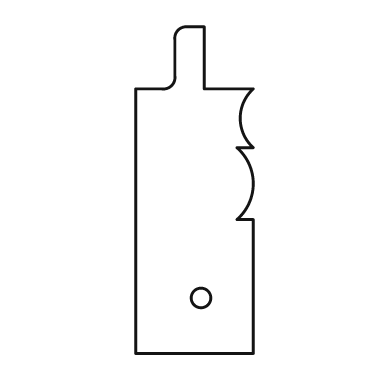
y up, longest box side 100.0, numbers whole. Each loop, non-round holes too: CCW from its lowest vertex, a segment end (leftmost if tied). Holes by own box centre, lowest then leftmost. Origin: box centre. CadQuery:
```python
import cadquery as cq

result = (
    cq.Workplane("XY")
    .moveTo(-18.0, -50.0)
    .lineTo(18.0, -50.0)
    .lineTo(18.0, -9.0)
    .lineTo(13.0, -9.0)
    .threePointArc((18.0, 2.0), (13.0, 13.0))
    .lineTo(18.0, 13.0)
    .threePointArc((14.0, 22.0), (18.0, 31.0))
    .lineTo(3.0, 31.0)
    .lineTo(3.0, 50.0)
    .lineTo(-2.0, 50.0)
    .threePointArc((-5.0, 49.0), (-6.0, 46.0))
    .lineTo(-6.0, 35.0)
    .threePointArc((-7.0, 32.0), (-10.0, 31.0))
    .lineTo(-18.0, 31.0)
    .close()
    .moveTo(2.0, -33.0)
    .circle(3.0)
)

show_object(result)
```